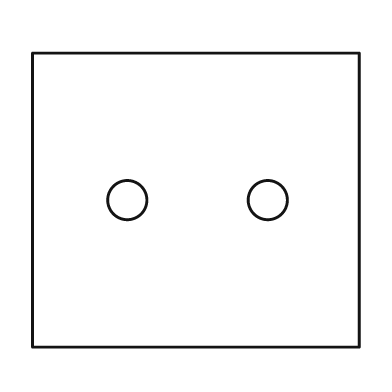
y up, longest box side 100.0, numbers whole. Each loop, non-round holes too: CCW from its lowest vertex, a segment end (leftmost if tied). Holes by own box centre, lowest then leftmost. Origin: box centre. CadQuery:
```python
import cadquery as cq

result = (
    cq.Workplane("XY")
    .moveTo(-50.0, -45.0)
    .lineTo(50.0, -45.0)
    .lineTo(50.0, 45.0)
    .lineTo(-50.0, 45.0)
    .close()
    .moveTo(-21.0, 0.0)
    .circle(6.0)
    .moveTo(22.0, 0.0)
    .circle(6.0)
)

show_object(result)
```